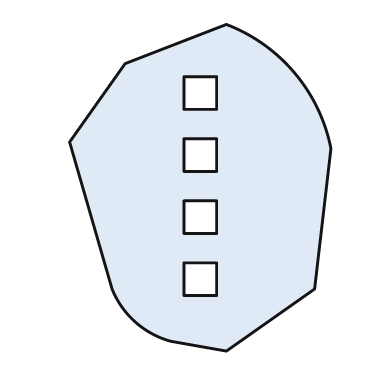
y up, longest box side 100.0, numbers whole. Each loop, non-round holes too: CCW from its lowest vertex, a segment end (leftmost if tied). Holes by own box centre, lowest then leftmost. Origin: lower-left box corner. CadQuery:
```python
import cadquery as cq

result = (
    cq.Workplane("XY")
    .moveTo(48.0, 0.0)
    .lineTo(75.0, 19.0)
    .lineTo(80.0, 62.0)
    .threePointArc((69.0, 85.0), (48.0, 100.0))
    .lineTo(17.0, 88.0)
    .lineTo(0.0, 64.0)
    .lineTo(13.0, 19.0)
    .threePointArc((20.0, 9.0), (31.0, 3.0))
    .close()
    .moveTo(35.0, 17.0)
    .lineTo(45.0, 17.0)
    .lineTo(45.0, 27.0)
    .lineTo(35.0, 27.0)
    .close()
    .moveTo(35.0, 36.0)
    .lineTo(45.0, 36.0)
    .lineTo(45.0, 46.0)
    .lineTo(35.0, 46.0)
    .close()
    .moveTo(35.0, 55.0)
    .lineTo(45.0, 55.0)
    .lineTo(45.0, 65.0)
    .lineTo(35.0, 65.0)
    .close()
    .moveTo(35.0, 74.0)
    .lineTo(45.0, 74.0)
    .lineTo(45.0, 84.0)
    .lineTo(35.0, 84.0)
    .close()
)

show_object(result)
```